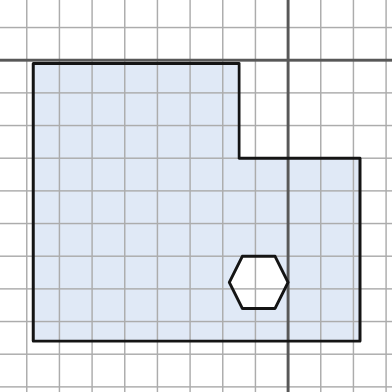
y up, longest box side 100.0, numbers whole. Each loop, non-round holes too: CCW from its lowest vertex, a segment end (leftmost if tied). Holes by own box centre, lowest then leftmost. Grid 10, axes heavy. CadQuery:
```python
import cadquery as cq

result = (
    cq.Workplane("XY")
    .moveTo(-78.0, -86.0)
    .lineTo(22.0, -86.0)
    .lineTo(22.0, -30.0)
    .lineTo(-15.0, -30.0)
    .lineTo(-15.0, -1.0)
    .lineTo(-78.0, -1.0)
    .close()
    .moveTo(-14.0, -76.0)
    .lineTo(-4.0, -76.0)
    .lineTo(0.0, -68.0)
    .lineTo(-4.0, -60.0)
    .lineTo(-14.0, -60.0)
    .lineTo(-18.0, -68.0)
    .close()
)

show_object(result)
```